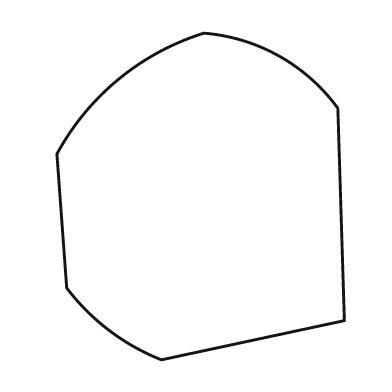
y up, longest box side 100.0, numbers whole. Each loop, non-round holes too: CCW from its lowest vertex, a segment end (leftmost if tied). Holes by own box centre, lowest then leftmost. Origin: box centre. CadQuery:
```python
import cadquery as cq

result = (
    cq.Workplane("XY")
    .moveTo(-12.0, -50.0)
    .lineTo(44.0, -38.0)
    .lineTo(42.0, 27.0)
    .threePointArc((24.0, 43.0), (1.0, 50.0))
    .threePointArc((-25.0, 36.0), (-44.0, 13.0))
    .lineTo(-41.0, -28.0)
    .threePointArc((-28.0, -41.0), (-12.0, -50.0))
    .close()
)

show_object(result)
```